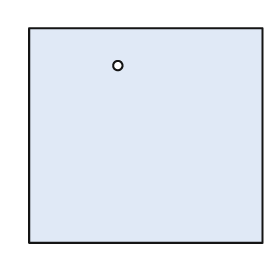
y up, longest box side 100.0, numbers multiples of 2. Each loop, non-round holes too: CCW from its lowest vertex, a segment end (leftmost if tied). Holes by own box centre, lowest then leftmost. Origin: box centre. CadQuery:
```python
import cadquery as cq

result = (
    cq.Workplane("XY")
    .moveTo(-50.0, -46.0)
    .lineTo(50.0, -46.0)
    .lineTo(50.0, 46.0)
    .lineTo(-50.0, 46.0)
    .close()
    .moveTo(-12.0, 30.0)
    .circle(2.0)
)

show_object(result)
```